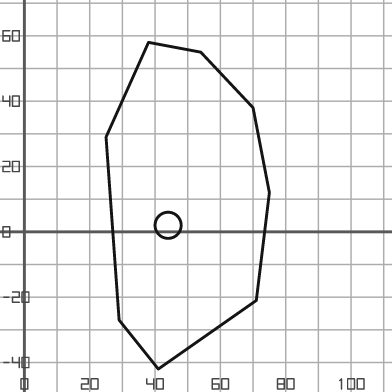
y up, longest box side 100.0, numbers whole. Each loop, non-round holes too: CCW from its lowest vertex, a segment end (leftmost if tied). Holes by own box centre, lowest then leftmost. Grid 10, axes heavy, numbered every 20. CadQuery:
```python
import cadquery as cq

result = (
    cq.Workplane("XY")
    .moveTo(41.0, -42.0)
    .lineTo(71.0, -21.0)
    .lineTo(75.0, 12.0)
    .lineTo(70.0, 38.0)
    .lineTo(54.0, 55.0)
    .lineTo(38.0, 58.0)
    .lineTo(25.0, 29.0)
    .lineTo(29.0, -27.0)
    .close()
    .moveTo(44.0, 2.0)
    .circle(4.0)
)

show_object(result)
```